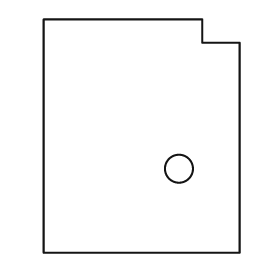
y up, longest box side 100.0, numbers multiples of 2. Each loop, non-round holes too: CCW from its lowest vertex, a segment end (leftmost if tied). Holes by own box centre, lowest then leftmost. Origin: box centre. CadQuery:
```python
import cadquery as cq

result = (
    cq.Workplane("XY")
    .moveTo(-42.0, -50.0)
    .lineTo(42.0, -50.0)
    .lineTo(42.0, 40.0)
    .lineTo(26.0, 40.0)
    .lineTo(26.0, 50.0)
    .lineTo(-42.0, 50.0)
    .close()
    .moveTo(16.0, -14.0)
    .circle(6.0)
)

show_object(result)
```